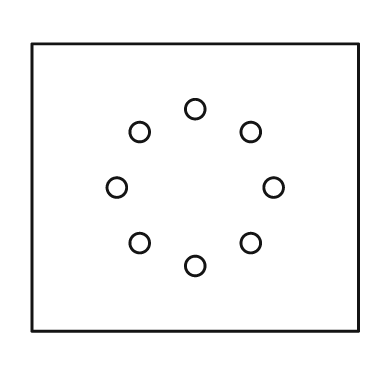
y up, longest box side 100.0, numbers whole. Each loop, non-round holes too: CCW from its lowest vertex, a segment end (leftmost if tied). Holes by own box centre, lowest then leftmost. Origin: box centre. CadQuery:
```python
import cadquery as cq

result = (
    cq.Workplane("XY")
    .moveTo(-50.0, -44.0)
    .lineTo(50.0, -44.0)
    .lineTo(50.0, 44.0)
    .lineTo(-50.0, 44.0)
    .close()
    .moveTo(0.0, -24.0)
    .circle(3.0)
    .moveTo(-17.0, -17.0)
    .circle(3.0)
    .moveTo(17.0, -17.0)
    .circle(3.0)
    .moveTo(-24.0, 0.0)
    .circle(3.0)
    .moveTo(24.0, 0.0)
    .circle(3.0)
    .moveTo(-17.0, 17.0)
    .circle(3.0)
    .moveTo(17.0, 17.0)
    .circle(3.0)
    .moveTo(0.0, 24.0)
    .circle(3.0)
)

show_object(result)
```